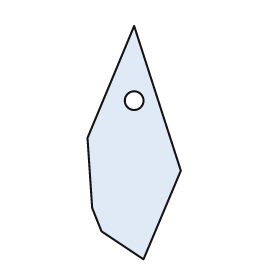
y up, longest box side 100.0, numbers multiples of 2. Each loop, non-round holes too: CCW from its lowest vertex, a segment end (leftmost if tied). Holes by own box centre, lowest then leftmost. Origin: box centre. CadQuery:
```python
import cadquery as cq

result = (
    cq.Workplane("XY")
    .moveTo(4.0, -50.0)
    .lineTo(20.0, -12.0)
    .lineTo(0.0, 50.0)
    .lineTo(-20.0, 2.0)
    .lineTo(-18.0, -28.0)
    .lineTo(-14.0, -38.0)
    .close()
    .moveTo(0.0, 18.0)
    .circle(4.0)
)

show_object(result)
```